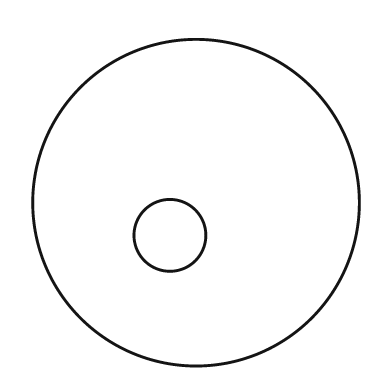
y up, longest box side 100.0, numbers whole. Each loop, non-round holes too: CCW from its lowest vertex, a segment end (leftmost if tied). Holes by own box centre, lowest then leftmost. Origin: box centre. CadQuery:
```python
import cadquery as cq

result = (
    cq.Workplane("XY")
    .moveTo(0.0, 0.0)
    .circle(50.0)
    .moveTo(-8.0, -10.0)
    .circle(11.0)
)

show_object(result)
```